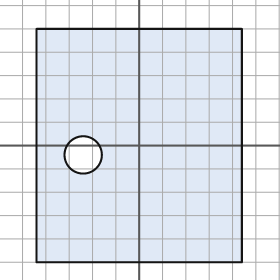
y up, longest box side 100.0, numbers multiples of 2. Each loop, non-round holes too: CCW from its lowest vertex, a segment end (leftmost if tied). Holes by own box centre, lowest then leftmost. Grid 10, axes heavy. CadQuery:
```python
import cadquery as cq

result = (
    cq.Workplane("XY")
    .moveTo(-44.0, -50.0)
    .lineTo(44.0, -50.0)
    .lineTo(44.0, 50.0)
    .lineTo(-44.0, 50.0)
    .close()
    .moveTo(-24.0, -4.0)
    .circle(8.0)
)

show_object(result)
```